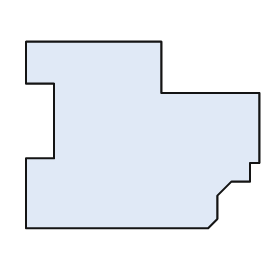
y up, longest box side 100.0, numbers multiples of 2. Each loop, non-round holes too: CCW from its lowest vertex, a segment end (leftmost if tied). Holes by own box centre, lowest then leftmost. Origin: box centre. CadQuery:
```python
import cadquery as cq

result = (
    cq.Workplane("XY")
    .moveTo(-50.0, -40.0)
    .lineTo(28.0, -40.0)
    .lineTo(32.0, -36.0)
    .lineTo(32.0, -26.0)
    .lineTo(38.0, -20.0)
    .lineTo(46.0, -20.0)
    .lineTo(46.0, -12.0)
    .lineTo(50.0, -12.0)
    .lineTo(50.0, 18.0)
    .lineTo(8.0, 18.0)
    .lineTo(8.0, 40.0)
    .lineTo(-50.0, 40.0)
    .lineTo(-50.0, 22.0)
    .lineTo(-38.0, 22.0)
    .lineTo(-38.0, -10.0)
    .lineTo(-50.0, -10.0)
    .close()
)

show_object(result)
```